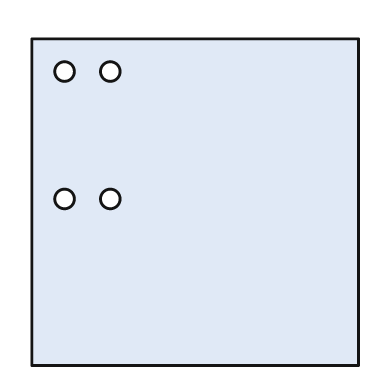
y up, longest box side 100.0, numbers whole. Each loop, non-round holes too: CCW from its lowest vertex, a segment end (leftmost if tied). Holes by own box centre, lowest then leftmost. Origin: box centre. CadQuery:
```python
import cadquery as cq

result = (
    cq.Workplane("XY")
    .moveTo(-50.0, -50.0)
    .lineTo(50.0, -50.0)
    .lineTo(50.0, 50.0)
    .lineTo(-50.0, 50.0)
    .close()
    .moveTo(-40.0, 1.0)
    .circle(3.0)
    .moveTo(-26.0, 1.0)
    .circle(3.0)
    .moveTo(-40.0, 40.0)
    .circle(3.0)
    .moveTo(-26.0, 40.0)
    .circle(3.0)
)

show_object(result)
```